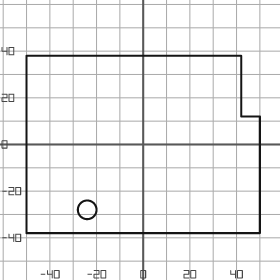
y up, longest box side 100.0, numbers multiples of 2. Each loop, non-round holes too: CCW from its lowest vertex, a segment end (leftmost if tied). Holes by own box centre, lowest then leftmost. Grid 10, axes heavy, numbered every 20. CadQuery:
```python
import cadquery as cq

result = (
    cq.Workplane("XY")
    .moveTo(-50.0, -38.0)
    .lineTo(50.0, -38.0)
    .lineTo(50.0, 12.0)
    .lineTo(42.0, 12.0)
    .lineTo(42.0, 38.0)
    .lineTo(-50.0, 38.0)
    .close()
    .moveTo(-24.0, -28.0)
    .circle(4.0)
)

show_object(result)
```